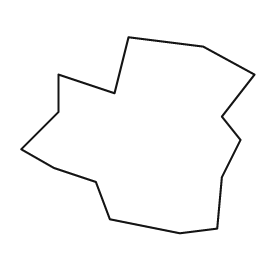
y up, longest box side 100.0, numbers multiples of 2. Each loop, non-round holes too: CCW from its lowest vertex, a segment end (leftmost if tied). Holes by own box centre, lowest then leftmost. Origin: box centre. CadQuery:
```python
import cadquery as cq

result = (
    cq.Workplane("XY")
    .moveTo(18.0, -42.0)
    .lineTo(34.0, -40.0)
    .lineTo(36.0, -18.0)
    .lineTo(44.0, -2.0)
    .lineTo(36.0, 8.0)
    .lineTo(50.0, 26.0)
    .lineTo(28.0, 38.0)
    .lineTo(-4.0, 42.0)
    .lineTo(-10.0, 18.0)
    .lineTo(-34.0, 26.0)
    .lineTo(-34.0, 10.0)
    .lineTo(-50.0, -6.0)
    .lineTo(-36.0, -14.0)
    .lineTo(-18.0, -20.0)
    .lineTo(-12.0, -36.0)
    .close()
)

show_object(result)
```